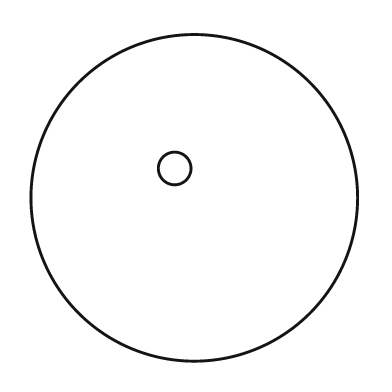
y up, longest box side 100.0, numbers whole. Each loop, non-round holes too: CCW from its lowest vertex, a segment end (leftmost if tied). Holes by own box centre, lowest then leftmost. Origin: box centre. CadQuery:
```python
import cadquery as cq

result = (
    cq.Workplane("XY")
    .moveTo(0.0, 0.0)
    .circle(50.0)
    .moveTo(-6.0, 9.0)
    .circle(5.0)
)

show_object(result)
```